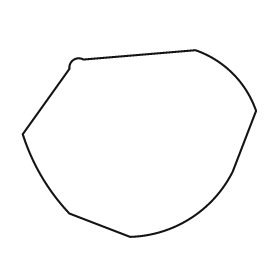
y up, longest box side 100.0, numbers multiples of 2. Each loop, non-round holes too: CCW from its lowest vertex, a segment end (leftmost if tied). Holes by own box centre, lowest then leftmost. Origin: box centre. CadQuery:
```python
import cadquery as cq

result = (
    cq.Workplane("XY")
    .moveTo(-4.0, -40.0)
    .threePointArc((22.0, -32.0), (40.0, -12.0))
    .lineTo(50.0, 14.0)
    .threePointArc((40.0, 30.0), (24.0, 40.0))
    .lineTo(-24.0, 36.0)
    .threePointArc((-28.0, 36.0), (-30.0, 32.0))
    .lineTo(-50.0, 4.0)
    .threePointArc((-42.0, -14.0), (-30.0, -30.0))
    .close()
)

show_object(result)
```